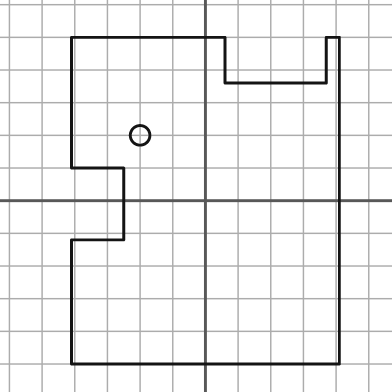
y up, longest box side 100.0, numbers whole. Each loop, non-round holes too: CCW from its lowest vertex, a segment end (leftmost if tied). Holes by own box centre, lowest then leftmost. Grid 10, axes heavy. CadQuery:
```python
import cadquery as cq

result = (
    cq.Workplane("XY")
    .moveTo(-41.0, -50.0)
    .lineTo(41.0, -50.0)
    .lineTo(41.0, 50.0)
    .lineTo(37.0, 50.0)
    .lineTo(37.0, 36.0)
    .lineTo(6.0, 36.0)
    .lineTo(6.0, 50.0)
    .lineTo(-41.0, 50.0)
    .lineTo(-41.0, 10.0)
    .lineTo(-25.0, 10.0)
    .lineTo(-25.0, -12.0)
    .lineTo(-41.0, -12.0)
    .close()
    .moveTo(-20.0, 20.0)
    .circle(3.0)
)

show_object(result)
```